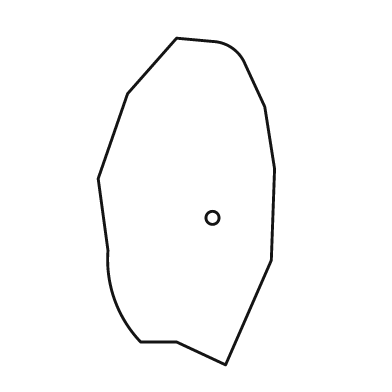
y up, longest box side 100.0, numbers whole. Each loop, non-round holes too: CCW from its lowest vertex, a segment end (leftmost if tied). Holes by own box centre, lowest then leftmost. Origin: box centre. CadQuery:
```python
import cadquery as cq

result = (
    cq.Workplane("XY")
    .moveTo(12.0, -50.0)
    .lineTo(26.0, -18.0)
    .lineTo(27.0, 10.0)
    .lineTo(24.0, 29.0)
    .lineTo(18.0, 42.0)
    .threePointArc((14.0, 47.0), (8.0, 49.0))
    .lineTo(-3.0, 50.0)
    .lineTo(-18.0, 33.0)
    .lineTo(-27.0, 7.0)
    .lineTo(-24.0, -15.0)
    .threePointArc((-22.0, -30.0), (-14.0, -43.0))
    .lineTo(-3.0, -43.0)
    .close()
    .moveTo(8.0, -5.0)
    .circle(2.0)
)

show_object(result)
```